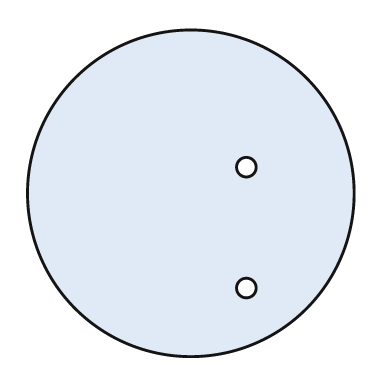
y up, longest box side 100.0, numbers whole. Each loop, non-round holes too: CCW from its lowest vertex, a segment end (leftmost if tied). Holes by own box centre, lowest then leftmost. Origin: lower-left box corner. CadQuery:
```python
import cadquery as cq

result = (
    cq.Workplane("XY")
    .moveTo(50.0, 50.0)
    .circle(50.0)
    .moveTo(67.0, 21.0)
    .circle(3.0)
    .moveTo(67.0, 58.0)
    .circle(3.0)
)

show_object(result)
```